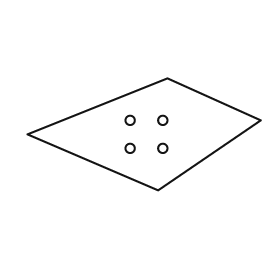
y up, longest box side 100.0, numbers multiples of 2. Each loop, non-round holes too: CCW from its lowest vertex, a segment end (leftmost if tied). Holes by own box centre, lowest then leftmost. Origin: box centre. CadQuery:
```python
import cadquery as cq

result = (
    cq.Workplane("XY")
    .moveTo(6.0, -24.0)
    .lineTo(50.0, 6.0)
    .lineTo(10.0, 24.0)
    .lineTo(-50.0, 0.0)
    .close()
    .moveTo(-6.0, -6.0)
    .circle(2.0)
    .moveTo(8.0, -6.0)
    .circle(2.0)
    .moveTo(-6.0, 6.0)
    .circle(2.0)
    .moveTo(8.0, 6.0)
    .circle(2.0)
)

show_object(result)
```